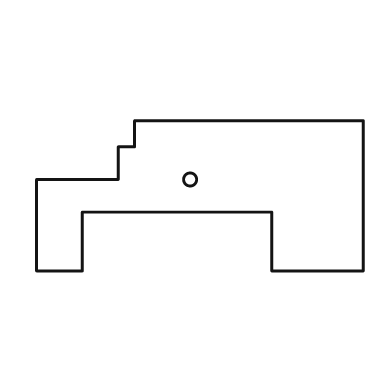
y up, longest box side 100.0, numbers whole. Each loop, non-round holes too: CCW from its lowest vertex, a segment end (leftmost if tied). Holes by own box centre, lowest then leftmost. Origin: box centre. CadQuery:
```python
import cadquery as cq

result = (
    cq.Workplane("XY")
    .moveTo(-50.0, -23.0)
    .lineTo(-36.0, -23.0)
    .lineTo(-36.0, -5.0)
    .lineTo(22.0, -5.0)
    .lineTo(22.0, -23.0)
    .lineTo(50.0, -23.0)
    .lineTo(50.0, 23.0)
    .lineTo(-20.0, 23.0)
    .lineTo(-20.0, 15.0)
    .lineTo(-25.0, 15.0)
    .lineTo(-25.0, 5.0)
    .lineTo(-50.0, 5.0)
    .close()
    .moveTo(-3.0, 5.0)
    .circle(2.0)
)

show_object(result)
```